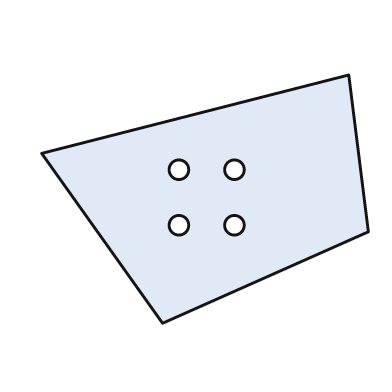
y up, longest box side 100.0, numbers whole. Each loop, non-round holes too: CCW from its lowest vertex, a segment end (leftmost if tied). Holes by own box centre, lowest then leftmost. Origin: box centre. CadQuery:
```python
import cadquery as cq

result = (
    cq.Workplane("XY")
    .moveTo(-13.0, -38.0)
    .lineTo(50.0, -10.0)
    .lineTo(44.0, 38.0)
    .lineTo(-50.0, 14.0)
    .close()
    .moveTo(-8.0, -8.0)
    .circle(3.0)
    .moveTo(9.0, -8.0)
    .circle(3.0)
    .moveTo(-8.0, 9.0)
    .circle(3.0)
    .moveTo(9.0, 9.0)
    .circle(3.0)
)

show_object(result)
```